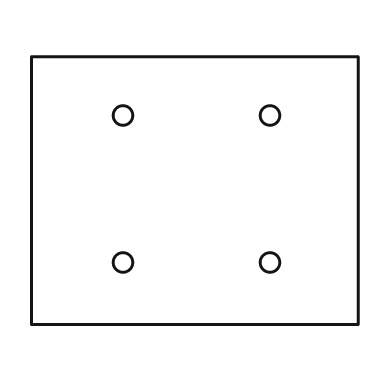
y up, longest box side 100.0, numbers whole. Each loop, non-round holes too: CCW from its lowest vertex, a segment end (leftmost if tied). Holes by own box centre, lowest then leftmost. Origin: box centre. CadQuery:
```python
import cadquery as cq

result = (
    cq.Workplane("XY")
    .moveTo(-50.0, -41.0)
    .lineTo(50.0, -41.0)
    .lineTo(50.0, 41.0)
    .lineTo(-50.0, 41.0)
    .close()
    .moveTo(-22.0, -22.0)
    .circle(3.0)
    .moveTo(23.0, -22.0)
    .circle(3.0)
    .moveTo(-22.0, 23.0)
    .circle(3.0)
    .moveTo(23.0, 23.0)
    .circle(3.0)
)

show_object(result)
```